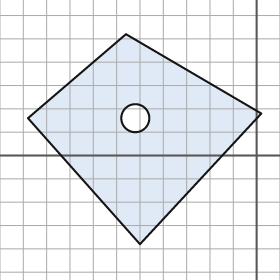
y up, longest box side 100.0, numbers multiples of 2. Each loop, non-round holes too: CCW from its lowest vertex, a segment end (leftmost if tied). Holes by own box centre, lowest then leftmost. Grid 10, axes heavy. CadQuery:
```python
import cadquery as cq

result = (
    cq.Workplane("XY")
    .moveTo(-50.0, -38.0)
    .lineTo(2.0, 18.0)
    .lineTo(-56.0, 52.0)
    .lineTo(-98.0, 16.0)
    .close()
    .moveTo(-52.0, 16.0)
    .circle(6.0)
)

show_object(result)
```